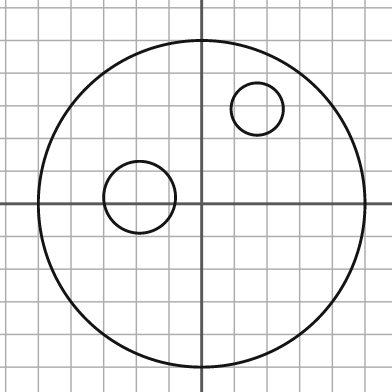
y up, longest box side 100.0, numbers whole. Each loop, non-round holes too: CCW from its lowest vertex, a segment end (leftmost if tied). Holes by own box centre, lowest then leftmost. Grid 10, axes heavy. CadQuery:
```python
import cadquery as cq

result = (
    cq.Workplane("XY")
    .moveTo(0.0, 0.0)
    .circle(50.0)
    .moveTo(-19.0, 2.0)
    .circle(11.0)
    .moveTo(17.0, 29.0)
    .circle(8.0)
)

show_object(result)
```